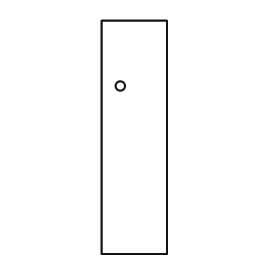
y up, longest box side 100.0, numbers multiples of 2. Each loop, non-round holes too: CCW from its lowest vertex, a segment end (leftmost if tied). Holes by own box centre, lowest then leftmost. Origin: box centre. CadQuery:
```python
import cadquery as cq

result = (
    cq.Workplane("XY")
    .moveTo(-14.0, -50.0)
    .lineTo(14.0, -50.0)
    .lineTo(14.0, 50.0)
    .lineTo(-14.0, 50.0)
    .close()
    .moveTo(-6.0, 22.0)
    .circle(2.0)
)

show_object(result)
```